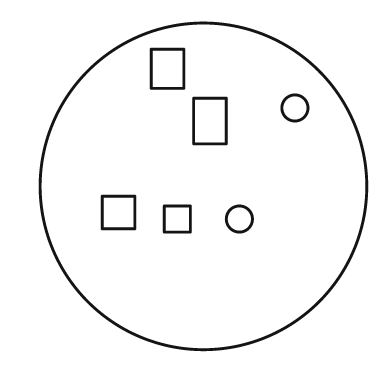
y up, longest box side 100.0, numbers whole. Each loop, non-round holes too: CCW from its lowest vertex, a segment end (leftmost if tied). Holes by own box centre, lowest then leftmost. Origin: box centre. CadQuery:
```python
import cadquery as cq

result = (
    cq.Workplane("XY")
    .moveTo(0.0, 0.0)
    .circle(50.0)
    .moveTo(-12.0, -14.0)
    .lineTo(-4.0, -14.0)
    .lineTo(-4.0, -6.0)
    .lineTo(-12.0, -6.0)
    .close()
    .moveTo(11.0, -10.0)
    .circle(4.0)
    .moveTo(-31.0, -13.0)
    .lineTo(-21.0, -13.0)
    .lineTo(-21.0, -3.0)
    .lineTo(-31.0, -3.0)
    .close()
    .moveTo(-3.0, 13.0)
    .lineTo(7.0, 13.0)
    .lineTo(7.0, 27.0)
    .lineTo(-3.0, 27.0)
    .close()
    .moveTo(28.0, 24.0)
    .circle(4.0)
    .moveTo(-16.0, 30.0)
    .lineTo(-6.0, 30.0)
    .lineTo(-6.0, 42.0)
    .lineTo(-16.0, 42.0)
    .close()
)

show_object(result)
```